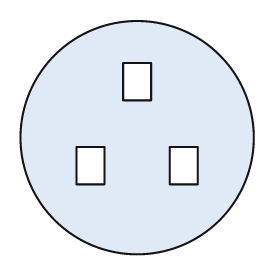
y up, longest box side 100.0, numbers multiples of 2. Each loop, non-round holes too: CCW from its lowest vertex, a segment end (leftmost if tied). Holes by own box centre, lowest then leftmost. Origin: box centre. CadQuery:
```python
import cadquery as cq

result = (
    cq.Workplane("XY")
    .moveTo(0.0, 0.0)
    .circle(50.0)
    .moveTo(-26.0, -20.0)
    .lineTo(-14.0, -20.0)
    .lineTo(-14.0, -4.0)
    .lineTo(-26.0, -4.0)
    .close()
    .moveTo(14.0, -20.0)
    .lineTo(26.0, -20.0)
    .lineTo(26.0, -4.0)
    .lineTo(14.0, -4.0)
    .close()
    .moveTo(-6.0, 16.0)
    .lineTo(6.0, 16.0)
    .lineTo(6.0, 32.0)
    .lineTo(-6.0, 32.0)
    .close()
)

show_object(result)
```